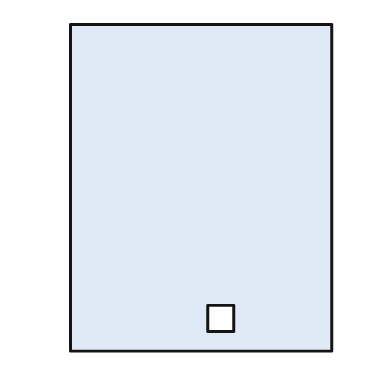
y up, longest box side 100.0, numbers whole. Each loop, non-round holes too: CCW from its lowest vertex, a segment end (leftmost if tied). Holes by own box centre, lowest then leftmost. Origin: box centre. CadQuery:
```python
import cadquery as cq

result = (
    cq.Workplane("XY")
    .moveTo(-40.0, -50.0)
    .lineTo(40.0, -50.0)
    .lineTo(40.0, 50.0)
    .lineTo(-40.0, 50.0)
    .close()
    .moveTo(2.0, -44.0)
    .lineTo(10.0, -44.0)
    .lineTo(10.0, -36.0)
    .lineTo(2.0, -36.0)
    .close()
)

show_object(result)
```